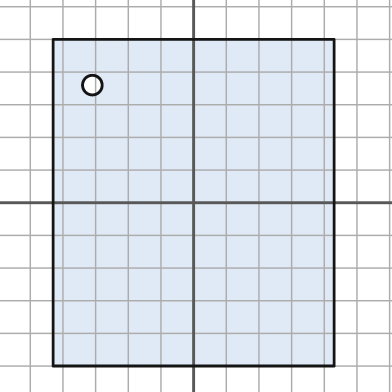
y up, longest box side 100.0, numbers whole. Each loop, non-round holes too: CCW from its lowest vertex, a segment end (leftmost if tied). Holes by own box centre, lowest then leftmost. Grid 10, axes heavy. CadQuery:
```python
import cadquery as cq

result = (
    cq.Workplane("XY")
    .moveTo(-43.0, -50.0)
    .lineTo(43.0, -50.0)
    .lineTo(43.0, 50.0)
    .lineTo(-43.0, 50.0)
    .close()
    .moveTo(-31.0, 36.0)
    .circle(3.0)
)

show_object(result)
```